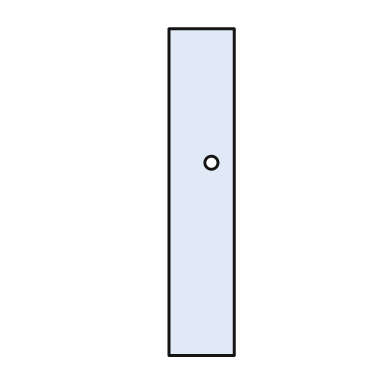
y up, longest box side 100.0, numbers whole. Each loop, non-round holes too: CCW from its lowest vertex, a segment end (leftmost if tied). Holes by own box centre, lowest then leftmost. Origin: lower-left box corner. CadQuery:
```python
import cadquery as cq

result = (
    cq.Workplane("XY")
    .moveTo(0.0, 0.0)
    .lineTo(20.0, 0.0)
    .lineTo(20.0, 100.0)
    .lineTo(0.0, 100.0)
    .close()
    .moveTo(13.0, 59.0)
    .circle(2.0)
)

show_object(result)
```